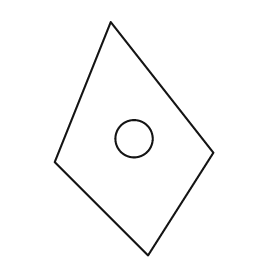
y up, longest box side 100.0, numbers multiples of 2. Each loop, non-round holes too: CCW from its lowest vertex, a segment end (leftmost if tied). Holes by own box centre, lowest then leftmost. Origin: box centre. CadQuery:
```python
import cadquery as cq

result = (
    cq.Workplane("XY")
    .moveTo(6.0, -50.0)
    .lineTo(34.0, -6.0)
    .lineTo(-10.0, 50.0)
    .lineTo(-34.0, -10.0)
    .close()
    .moveTo(0.0, 0.0)
    .circle(8.0)
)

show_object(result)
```